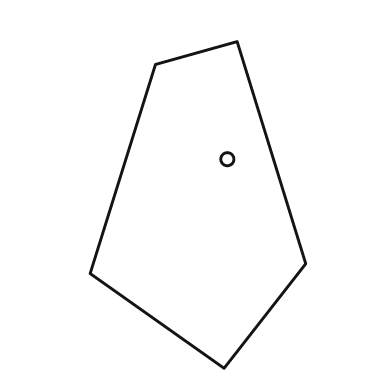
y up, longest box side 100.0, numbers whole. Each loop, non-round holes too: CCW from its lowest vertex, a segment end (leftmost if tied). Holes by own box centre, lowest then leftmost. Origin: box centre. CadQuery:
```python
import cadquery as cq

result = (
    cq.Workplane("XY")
    .moveTo(8.0, -50.0)
    .lineTo(33.0, -18.0)
    .lineTo(12.0, 50.0)
    .lineTo(-13.0, 43.0)
    .lineTo(-33.0, -21.0)
    .close()
    .moveTo(9.0, 14.0)
    .circle(2.0)
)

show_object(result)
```